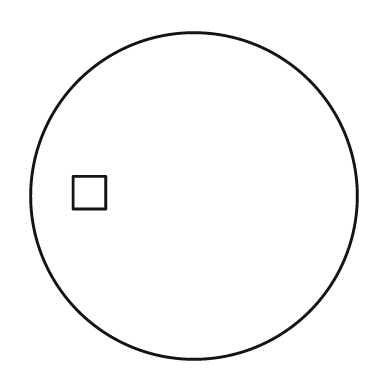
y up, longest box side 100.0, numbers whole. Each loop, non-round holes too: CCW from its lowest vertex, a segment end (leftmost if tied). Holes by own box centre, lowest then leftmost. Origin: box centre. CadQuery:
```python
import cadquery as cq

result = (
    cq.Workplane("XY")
    .moveTo(0.0, 0.0)
    .circle(50.0)
    .moveTo(-37.0, -4.0)
    .lineTo(-27.0, -4.0)
    .lineTo(-27.0, 6.0)
    .lineTo(-37.0, 6.0)
    .close()
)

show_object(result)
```